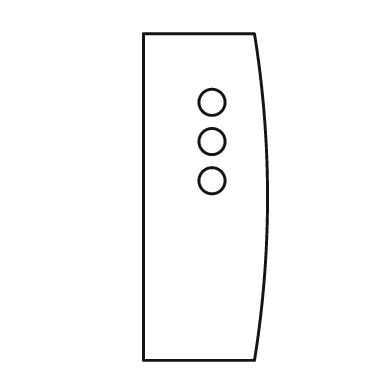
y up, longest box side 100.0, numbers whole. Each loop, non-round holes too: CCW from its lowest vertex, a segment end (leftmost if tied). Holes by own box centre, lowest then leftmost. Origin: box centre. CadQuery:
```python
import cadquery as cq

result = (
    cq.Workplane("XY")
    .moveTo(-19.0, -50.0)
    .lineTo(15.0, -50.0)
    .threePointArc((19.0, 0.0), (15.0, 50.0))
    .lineTo(-19.0, 50.0)
    .close()
    .moveTo(2.0, 5.0)
    .circle(4.0)
    .moveTo(2.0, 17.0)
    .circle(4.0)
    .moveTo(2.0, 29.0)
    .circle(4.0)
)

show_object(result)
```